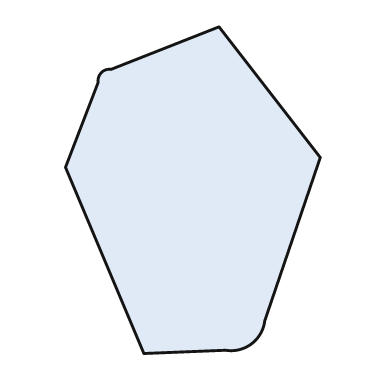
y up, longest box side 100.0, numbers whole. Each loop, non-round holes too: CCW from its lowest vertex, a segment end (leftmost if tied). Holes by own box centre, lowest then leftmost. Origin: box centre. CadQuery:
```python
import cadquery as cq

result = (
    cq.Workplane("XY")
    .moveTo(-15.0, -50.0)
    .lineTo(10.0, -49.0)
    .threePointArc((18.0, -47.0), (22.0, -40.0))
    .lineTo(39.0, 10.0)
    .lineTo(8.0, 50.0)
    .lineTo(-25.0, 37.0)
    .threePointArc((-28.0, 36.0), (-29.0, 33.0))
    .lineTo(-39.0, 7.0)
    .close()
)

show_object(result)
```